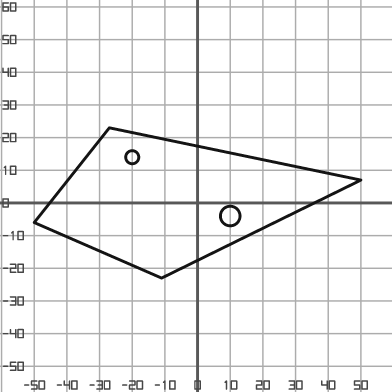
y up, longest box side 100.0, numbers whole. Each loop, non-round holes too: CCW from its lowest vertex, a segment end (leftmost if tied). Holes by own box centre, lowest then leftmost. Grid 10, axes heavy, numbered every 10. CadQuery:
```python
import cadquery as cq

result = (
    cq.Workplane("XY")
    .moveTo(-11.0, -23.0)
    .lineTo(50.0, 7.0)
    .lineTo(-27.0, 23.0)
    .lineTo(-50.0, -6.0)
    .close()
    .moveTo(10.0, -4.0)
    .circle(3.0)
    .moveTo(-20.0, 14.0)
    .circle(2.0)
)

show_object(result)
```